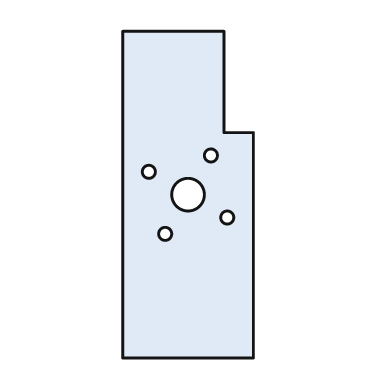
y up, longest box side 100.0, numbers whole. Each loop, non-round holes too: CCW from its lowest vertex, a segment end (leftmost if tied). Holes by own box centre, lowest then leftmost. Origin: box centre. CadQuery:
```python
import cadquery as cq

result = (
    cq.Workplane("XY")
    .moveTo(-20.0, -50.0)
    .lineTo(20.0, -50.0)
    .lineTo(20.0, 19.0)
    .lineTo(11.0, 19.0)
    .lineTo(11.0, 50.0)
    .lineTo(-20.0, 50.0)
    .close()
    .moveTo(-7.0, -12.0)
    .circle(2.0)
    .moveTo(12.0, -7.0)
    .circle(2.0)
    .moveTo(0.0, 0.0)
    .circle(5.0)
    .moveTo(-12.0, 7.0)
    .circle(2.0)
    .moveTo(7.0, 12.0)
    .circle(2.0)
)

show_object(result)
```